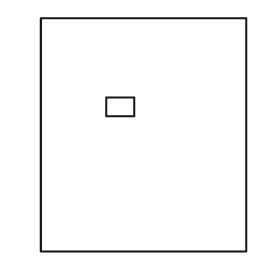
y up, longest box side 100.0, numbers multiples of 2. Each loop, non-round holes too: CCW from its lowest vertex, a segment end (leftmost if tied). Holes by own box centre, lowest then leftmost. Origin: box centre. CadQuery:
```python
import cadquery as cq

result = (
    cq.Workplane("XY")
    .moveTo(-44.0, -50.0)
    .lineTo(44.0, -50.0)
    .lineTo(44.0, 50.0)
    .lineTo(-44.0, 50.0)
    .close()
    .moveTo(-16.0, 8.0)
    .lineTo(-4.0, 8.0)
    .lineTo(-4.0, 16.0)
    .lineTo(-16.0, 16.0)
    .close()
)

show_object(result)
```